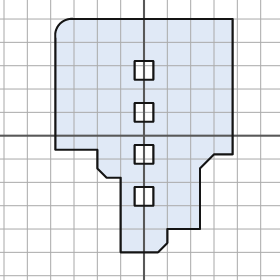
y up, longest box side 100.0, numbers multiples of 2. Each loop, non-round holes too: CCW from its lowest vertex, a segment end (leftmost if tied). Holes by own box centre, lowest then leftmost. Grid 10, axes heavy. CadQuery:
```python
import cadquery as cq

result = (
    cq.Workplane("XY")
    .moveTo(-10.0, -50.0)
    .lineTo(6.0, -50.0)
    .lineTo(10.0, -46.0)
    .lineTo(10.0, -40.0)
    .lineTo(24.0, -40.0)
    .lineTo(24.0, -14.0)
    .lineTo(30.0, -8.0)
    .lineTo(38.0, -8.0)
    .lineTo(38.0, 50.0)
    .lineTo(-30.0, 50.0)
    .threePointArc((-36.0, 48.0), (-38.0, 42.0))
    .lineTo(-38.0, -6.0)
    .lineTo(-20.0, -6.0)
    .lineTo(-20.0, -14.0)
    .lineTo(-16.0, -18.0)
    .lineTo(-10.0, -18.0)
    .close()
    .moveTo(-4.0, -30.0)
    .lineTo(4.0, -30.0)
    .lineTo(4.0, -22.0)
    .lineTo(-4.0, -22.0)
    .close()
    .moveTo(-4.0, -12.0)
    .lineTo(4.0, -12.0)
    .lineTo(4.0, -4.0)
    .lineTo(-4.0, -4.0)
    .close()
    .moveTo(-4.0, 6.0)
    .lineTo(4.0, 6.0)
    .lineTo(4.0, 14.0)
    .lineTo(-4.0, 14.0)
    .close()
    .moveTo(-4.0, 24.0)
    .lineTo(4.0, 24.0)
    .lineTo(4.0, 32.0)
    .lineTo(-4.0, 32.0)
    .close()
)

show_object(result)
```